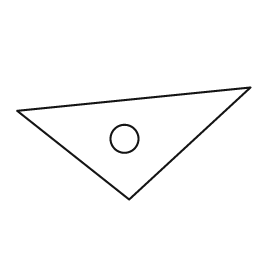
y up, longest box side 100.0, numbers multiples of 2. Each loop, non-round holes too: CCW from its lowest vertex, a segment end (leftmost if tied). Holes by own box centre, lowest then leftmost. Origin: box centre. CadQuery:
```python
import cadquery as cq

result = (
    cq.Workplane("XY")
    .moveTo(-2.0, -24.0)
    .lineTo(50.0, 24.0)
    .lineTo(-50.0, 14.0)
    .close()
    .moveTo(-4.0, 2.0)
    .circle(6.0)
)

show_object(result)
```